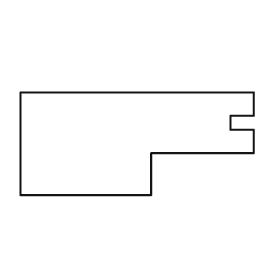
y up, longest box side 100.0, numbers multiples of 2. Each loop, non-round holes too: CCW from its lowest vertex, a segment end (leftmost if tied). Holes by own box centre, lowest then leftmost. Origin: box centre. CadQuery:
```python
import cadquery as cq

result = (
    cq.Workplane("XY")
    .moveTo(-50.0, -22.0)
    .lineTo(6.0, -22.0)
    .lineTo(6.0, -4.0)
    .lineTo(50.0, -4.0)
    .lineTo(50.0, 6.0)
    .lineTo(40.0, 6.0)
    .lineTo(40.0, 12.0)
    .lineTo(50.0, 12.0)
    .lineTo(50.0, 22.0)
    .lineTo(-50.0, 22.0)
    .close()
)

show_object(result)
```